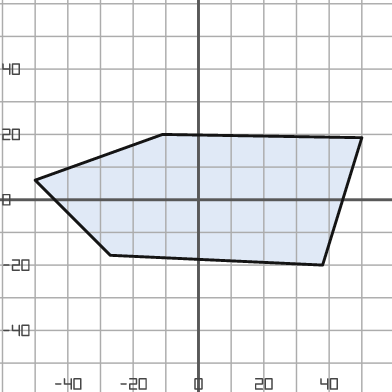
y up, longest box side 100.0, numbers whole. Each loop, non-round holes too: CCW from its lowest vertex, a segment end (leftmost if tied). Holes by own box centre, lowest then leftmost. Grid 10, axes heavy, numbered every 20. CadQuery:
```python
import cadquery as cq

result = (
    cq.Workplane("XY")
    .moveTo(38.0, -20.0)
    .lineTo(50.0, 19.0)
    .lineTo(-11.0, 20.0)
    .lineTo(-50.0, 6.0)
    .lineTo(-27.0, -17.0)
    .close()
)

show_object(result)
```